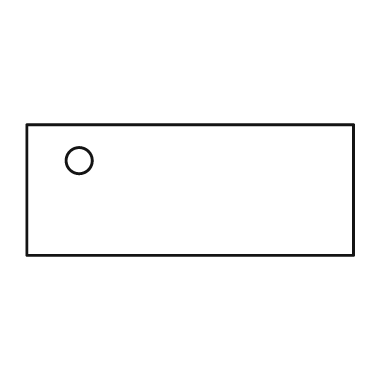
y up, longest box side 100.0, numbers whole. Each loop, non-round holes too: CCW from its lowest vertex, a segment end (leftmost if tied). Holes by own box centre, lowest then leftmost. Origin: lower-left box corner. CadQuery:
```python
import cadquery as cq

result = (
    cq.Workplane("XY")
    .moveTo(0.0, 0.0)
    .lineTo(100.0, 0.0)
    .lineTo(100.0, 40.0)
    .lineTo(0.0, 40.0)
    .close()
    .moveTo(16.0, 29.0)
    .circle(4.0)
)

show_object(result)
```